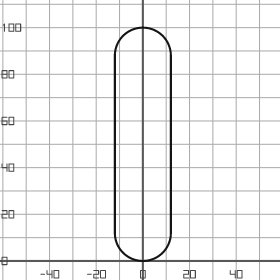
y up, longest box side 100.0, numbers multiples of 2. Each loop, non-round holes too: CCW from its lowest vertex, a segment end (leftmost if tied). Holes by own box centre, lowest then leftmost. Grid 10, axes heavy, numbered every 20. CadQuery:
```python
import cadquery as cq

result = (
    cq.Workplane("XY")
    .moveTo(-12.0, 12.0)
    .threePointArc((0.0, 0.0), (12.0, 12.0))
    .lineTo(12.0, 88.0)
    .threePointArc((0.0, 100.0), (-12.0, 88.0))
    .close()
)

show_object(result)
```